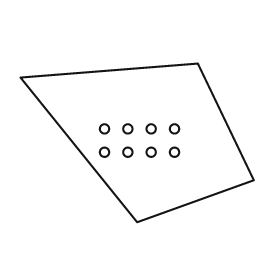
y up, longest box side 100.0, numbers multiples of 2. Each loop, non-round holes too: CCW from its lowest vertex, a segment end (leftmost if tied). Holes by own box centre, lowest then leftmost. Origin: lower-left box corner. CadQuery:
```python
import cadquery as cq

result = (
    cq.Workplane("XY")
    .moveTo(50.0, 0.0)
    .lineTo(100.0, 18.0)
    .lineTo(76.0, 68.0)
    .lineTo(0.0, 62.0)
    .close()
    .moveTo(36.0, 30.0)
    .circle(2.0)
    .moveTo(46.0, 30.0)
    .circle(2.0)
    .moveTo(56.0, 30.0)
    .circle(2.0)
    .moveTo(66.0, 30.0)
    .circle(2.0)
    .moveTo(36.0, 40.0)
    .circle(2.0)
    .moveTo(46.0, 40.0)
    .circle(2.0)
    .moveTo(56.0, 40.0)
    .circle(2.0)
    .moveTo(66.0, 40.0)
    .circle(2.0)
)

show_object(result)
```